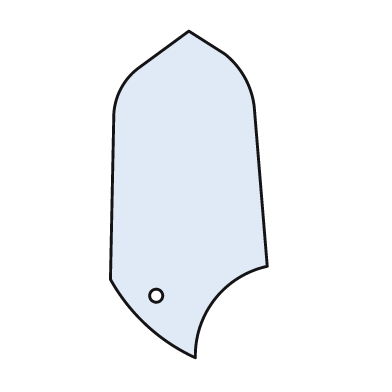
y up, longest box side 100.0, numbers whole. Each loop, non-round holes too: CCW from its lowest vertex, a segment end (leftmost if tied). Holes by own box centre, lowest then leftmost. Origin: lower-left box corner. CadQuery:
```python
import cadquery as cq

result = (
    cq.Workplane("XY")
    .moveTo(26.0, 0.0)
    .threePointArc((32.0, 18.0), (48.0, 28.0))
    .lineTo(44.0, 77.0)
    .threePointArc((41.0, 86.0), (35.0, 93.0))
    .lineTo(24.0, 100.0)
    .lineTo(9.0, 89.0)
    .threePointArc((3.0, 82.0), (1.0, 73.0))
    .lineTo(0.0, 24.0)
    .threePointArc((11.0, 10.0), (26.0, 0.0))
    .close()
    .moveTo(14.0, 19.0)
    .circle(2.0)
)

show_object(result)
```